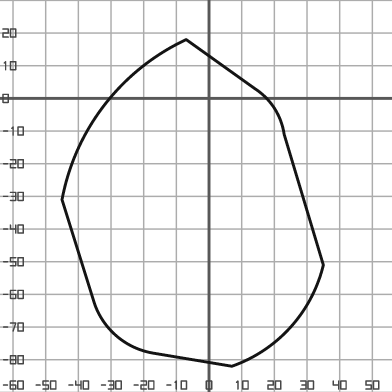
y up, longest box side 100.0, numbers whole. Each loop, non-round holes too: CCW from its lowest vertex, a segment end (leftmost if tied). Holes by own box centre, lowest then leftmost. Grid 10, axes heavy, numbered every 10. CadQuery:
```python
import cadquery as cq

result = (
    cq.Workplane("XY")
    .moveTo(7.0, -82.0)
    .threePointArc((25.0, -70.0), (35.0, -51.0))
    .lineTo(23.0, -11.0)
    .threePointArc((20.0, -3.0), (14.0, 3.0))
    .lineTo(-7.0, 18.0)
    .threePointArc((-32.0, -2.0), (-45.0, -31.0))
    .lineTo(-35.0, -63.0)
    .threePointArc((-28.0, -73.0), (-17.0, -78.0))
    .close()
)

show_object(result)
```